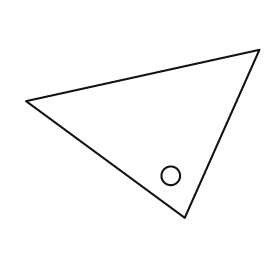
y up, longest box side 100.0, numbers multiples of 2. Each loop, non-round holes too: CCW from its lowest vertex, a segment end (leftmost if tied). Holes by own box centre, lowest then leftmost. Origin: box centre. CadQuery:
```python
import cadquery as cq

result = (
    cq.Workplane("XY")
    .moveTo(18.0, -36.0)
    .lineTo(50.0, 36.0)
    .lineTo(-50.0, 14.0)
    .close()
    .moveTo(12.0, -18.0)
    .circle(4.0)
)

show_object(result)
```